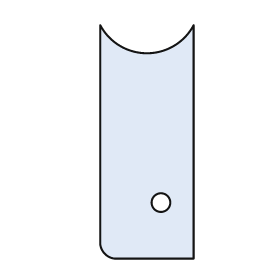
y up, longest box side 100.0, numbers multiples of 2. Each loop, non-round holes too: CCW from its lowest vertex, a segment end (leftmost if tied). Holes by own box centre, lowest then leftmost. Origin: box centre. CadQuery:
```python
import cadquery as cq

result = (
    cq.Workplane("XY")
    .moveTo(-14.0, -50.0)
    .lineTo(20.0, -50.0)
    .lineTo(20.0, 50.0)
    .threePointArc((0.0, 38.0), (-20.0, 50.0))
    .lineTo(-20.0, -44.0)
    .threePointArc((-18.0, -48.0), (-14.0, -50.0))
    .close()
    .moveTo(6.0, -26.0)
    .circle(4.0)
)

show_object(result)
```